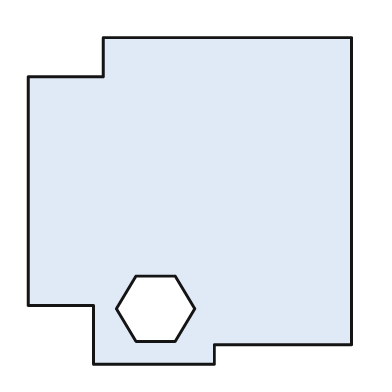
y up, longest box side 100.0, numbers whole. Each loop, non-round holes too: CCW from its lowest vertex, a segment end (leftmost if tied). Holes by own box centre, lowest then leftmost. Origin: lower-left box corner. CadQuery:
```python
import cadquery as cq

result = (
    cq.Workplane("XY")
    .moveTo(20.0, 0.0)
    .lineTo(57.0, 0.0)
    .lineTo(57.0, 6.0)
    .lineTo(99.0, 6.0)
    .lineTo(99.0, 100.0)
    .lineTo(23.0, 100.0)
    .lineTo(23.0, 88.0)
    .lineTo(0.0, 88.0)
    .lineTo(0.0, 18.0)
    .lineTo(20.0, 18.0)
    .close()
    .moveTo(33.0, 7.0)
    .lineTo(45.0, 7.0)
    .lineTo(51.0, 17.0)
    .lineTo(45.0, 27.0)
    .lineTo(33.0, 27.0)
    .lineTo(27.0, 17.0)
    .close()
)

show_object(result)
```